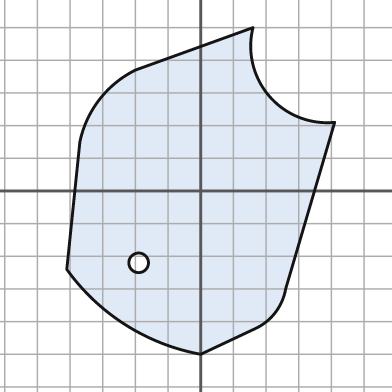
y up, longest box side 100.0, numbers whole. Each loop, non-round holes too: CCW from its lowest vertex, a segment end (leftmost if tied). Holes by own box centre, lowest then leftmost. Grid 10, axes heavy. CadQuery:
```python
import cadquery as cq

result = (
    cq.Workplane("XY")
    .moveTo(0.0, -50.0)
    .lineTo(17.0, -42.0)
    .threePointArc((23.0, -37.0), (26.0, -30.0))
    .lineTo(41.0, 21.0)
    .threePointArc((21.0, 29.0), (16.0, 50.0))
    .lineTo(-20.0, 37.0)
    .threePointArc((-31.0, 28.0), (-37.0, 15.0))
    .lineTo(-41.0, -24.0)
    .threePointArc((-23.0, -41.0), (0.0, -50.0))
    .close()
    .moveTo(-19.0, -22.0)
    .circle(3.0)
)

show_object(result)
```